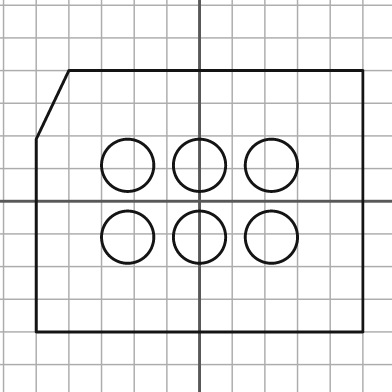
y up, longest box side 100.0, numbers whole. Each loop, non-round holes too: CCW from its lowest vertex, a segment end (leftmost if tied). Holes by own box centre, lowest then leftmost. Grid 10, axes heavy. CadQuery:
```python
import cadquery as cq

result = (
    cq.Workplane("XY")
    .moveTo(-50.0, -40.0)
    .lineTo(50.0, -40.0)
    .lineTo(50.0, 40.0)
    .lineTo(-40.0, 40.0)
    .lineTo(-50.0, 19.0)
    .close()
    .moveTo(-22.0, -11.0)
    .circle(8.0)
    .moveTo(0.0, -11.0)
    .circle(8.0)
    .moveTo(22.0, -11.0)
    .circle(8.0)
    .moveTo(-22.0, 11.0)
    .circle(8.0)
    .moveTo(0.0, 11.0)
    .circle(8.0)
    .moveTo(22.0, 11.0)
    .circle(8.0)
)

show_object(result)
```